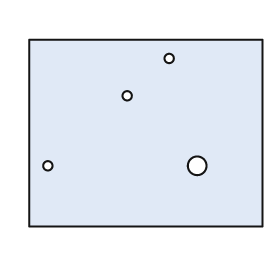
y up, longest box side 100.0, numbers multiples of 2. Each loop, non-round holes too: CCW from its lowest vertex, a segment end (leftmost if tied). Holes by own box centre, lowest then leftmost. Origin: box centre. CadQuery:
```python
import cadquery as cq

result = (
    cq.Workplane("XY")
    .moveTo(-50.0, -40.0)
    .lineTo(50.0, -40.0)
    .lineTo(50.0, 40.0)
    .lineTo(-50.0, 40.0)
    .close()
    .moveTo(-42.0, -14.0)
    .circle(2.0)
    .moveTo(22.0, -14.0)
    .circle(4.0)
    .moveTo(-8.0, 16.0)
    .circle(2.0)
    .moveTo(10.0, 32.0)
    .circle(2.0)
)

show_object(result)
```